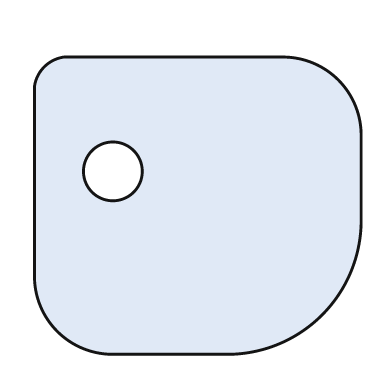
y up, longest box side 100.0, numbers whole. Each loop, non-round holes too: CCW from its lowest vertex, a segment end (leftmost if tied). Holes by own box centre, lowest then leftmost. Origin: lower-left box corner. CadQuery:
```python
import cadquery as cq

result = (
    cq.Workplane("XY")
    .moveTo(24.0, 0.0)
    .lineTo(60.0, 0.0)
    .threePointArc((88.0, 12.0), (100.0, 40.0))
    .lineTo(100.0, 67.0)
    .threePointArc((93.0, 84.0), (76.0, 91.0))
    .lineTo(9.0, 91.0)
    .threePointArc((3.0, 88.0), (0.0, 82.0))
    .lineTo(0.0, 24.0)
    .threePointArc((7.0, 7.0), (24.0, 0.0))
    .close()
    .moveTo(24.0, 56.0)
    .circle(9.0)
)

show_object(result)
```